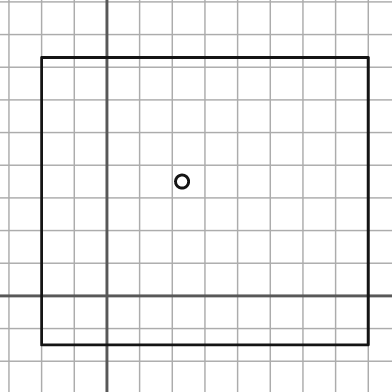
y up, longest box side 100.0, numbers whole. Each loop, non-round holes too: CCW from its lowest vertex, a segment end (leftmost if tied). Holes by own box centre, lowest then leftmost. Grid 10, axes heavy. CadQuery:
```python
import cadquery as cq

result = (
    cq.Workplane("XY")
    .moveTo(-20.0, -15.0)
    .lineTo(80.0, -15.0)
    .lineTo(80.0, 73.0)
    .lineTo(-20.0, 73.0)
    .close()
    .moveTo(23.0, 35.0)
    .circle(2.0)
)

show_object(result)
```